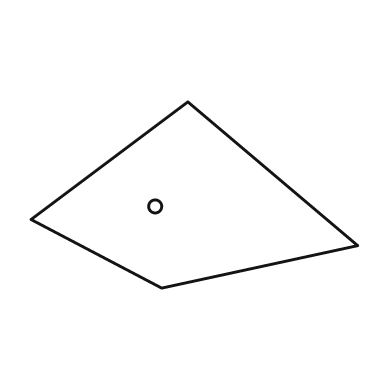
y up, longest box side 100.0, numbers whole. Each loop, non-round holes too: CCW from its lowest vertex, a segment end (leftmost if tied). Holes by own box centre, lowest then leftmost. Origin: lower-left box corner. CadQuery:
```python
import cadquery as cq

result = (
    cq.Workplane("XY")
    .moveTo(40.0, 0.0)
    .lineTo(100.0, 13.0)
    .lineTo(48.0, 57.0)
    .lineTo(0.0, 21.0)
    .close()
    .moveTo(38.0, 25.0)
    .circle(2.0)
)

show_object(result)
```